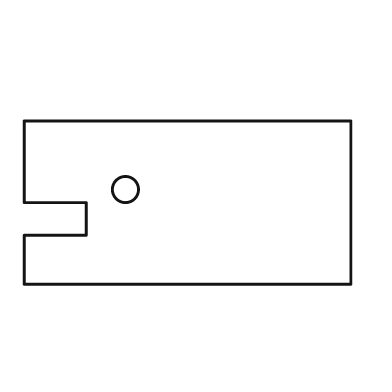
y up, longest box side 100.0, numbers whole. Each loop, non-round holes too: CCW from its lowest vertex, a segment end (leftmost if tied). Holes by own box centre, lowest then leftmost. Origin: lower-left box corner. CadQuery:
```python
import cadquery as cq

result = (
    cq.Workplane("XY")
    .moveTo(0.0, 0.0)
    .lineTo(100.0, 0.0)
    .lineTo(100.0, 50.0)
    .lineTo(0.0, 50.0)
    .lineTo(0.0, 25.0)
    .lineTo(19.0, 25.0)
    .lineTo(19.0, 15.0)
    .lineTo(0.0, 15.0)
    .close()
    .moveTo(31.0, 29.0)
    .circle(4.0)
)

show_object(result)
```